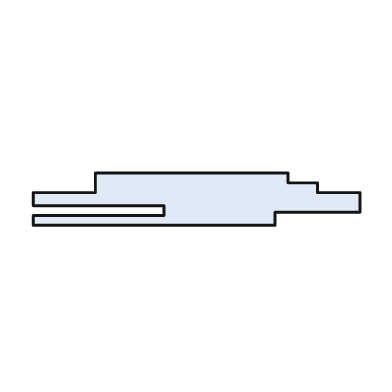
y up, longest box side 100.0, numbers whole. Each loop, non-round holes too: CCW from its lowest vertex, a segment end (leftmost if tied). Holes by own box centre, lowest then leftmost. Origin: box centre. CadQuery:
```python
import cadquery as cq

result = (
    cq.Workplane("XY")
    .moveTo(-50.0, -8.0)
    .lineTo(24.0, -8.0)
    .lineTo(24.0, -4.0)
    .lineTo(50.0, -4.0)
    .lineTo(50.0, 2.0)
    .lineTo(37.0, 2.0)
    .lineTo(37.0, 5.0)
    .lineTo(28.0, 5.0)
    .lineTo(28.0, 8.0)
    .lineTo(-31.0, 8.0)
    .lineTo(-31.0, 2.0)
    .lineTo(-50.0, 2.0)
    .lineTo(-50.0, -2.0)
    .lineTo(-10.0, -2.0)
    .lineTo(-10.0, -5.0)
    .lineTo(-50.0, -5.0)
    .close()
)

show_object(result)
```